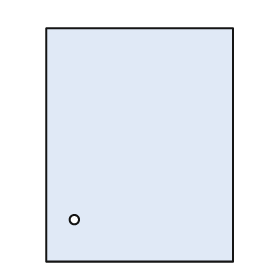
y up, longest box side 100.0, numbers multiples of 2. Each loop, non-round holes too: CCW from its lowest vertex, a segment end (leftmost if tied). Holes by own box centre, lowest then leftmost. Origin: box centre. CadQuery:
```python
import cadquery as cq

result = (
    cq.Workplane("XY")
    .moveTo(-40.0, -50.0)
    .lineTo(40.0, -50.0)
    .lineTo(40.0, 50.0)
    .lineTo(-40.0, 50.0)
    .close()
    .moveTo(-28.0, -32.0)
    .circle(2.0)
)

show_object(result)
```